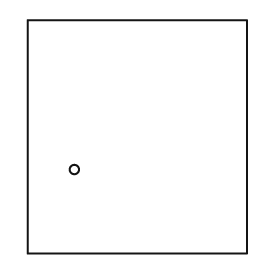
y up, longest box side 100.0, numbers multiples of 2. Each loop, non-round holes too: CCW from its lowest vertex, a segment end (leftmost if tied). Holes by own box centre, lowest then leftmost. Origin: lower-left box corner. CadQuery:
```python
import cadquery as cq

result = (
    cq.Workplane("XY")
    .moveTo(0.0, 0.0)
    .lineTo(94.0, 0.0)
    .lineTo(94.0, 100.0)
    .lineTo(0.0, 100.0)
    .close()
    .moveTo(20.0, 36.0)
    .circle(2.0)
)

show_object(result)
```